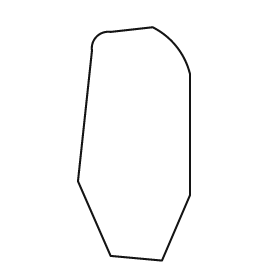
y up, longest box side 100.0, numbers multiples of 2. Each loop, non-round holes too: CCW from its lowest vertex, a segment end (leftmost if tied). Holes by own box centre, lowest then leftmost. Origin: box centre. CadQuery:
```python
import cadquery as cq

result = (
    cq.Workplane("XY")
    .moveTo(12.0, -50.0)
    .lineTo(24.0, -22.0)
    .lineTo(24.0, 30.0)
    .threePointArc((18.0, 42.0), (8.0, 50.0))
    .lineTo(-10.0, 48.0)
    .threePointArc((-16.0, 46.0), (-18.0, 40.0))
    .lineTo(-24.0, -16.0)
    .lineTo(-10.0, -48.0)
    .close()
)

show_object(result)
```